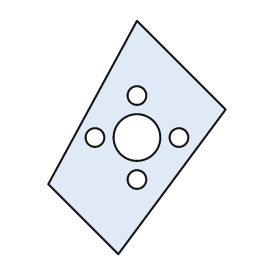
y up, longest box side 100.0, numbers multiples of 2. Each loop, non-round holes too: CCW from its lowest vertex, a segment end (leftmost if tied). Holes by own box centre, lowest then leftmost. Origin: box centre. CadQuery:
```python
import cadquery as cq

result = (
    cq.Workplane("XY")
    .moveTo(-8.0, -50.0)
    .lineTo(38.0, 12.0)
    .lineTo(0.0, 50.0)
    .lineTo(-38.0, -20.0)
    .close()
    .moveTo(0.0, -18.0)
    .circle(4.0)
    .moveTo(-18.0, 0.0)
    .circle(4.0)
    .moveTo(0.0, 0.0)
    .circle(10.0)
    .moveTo(18.0, 0.0)
    .circle(4.0)
    .moveTo(0.0, 18.0)
    .circle(4.0)
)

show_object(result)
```